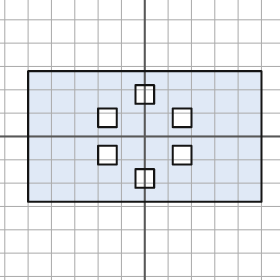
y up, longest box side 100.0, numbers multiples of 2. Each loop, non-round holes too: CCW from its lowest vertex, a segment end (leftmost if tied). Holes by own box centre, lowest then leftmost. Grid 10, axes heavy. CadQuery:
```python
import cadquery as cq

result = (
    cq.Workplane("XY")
    .moveTo(-50.0, -28.0)
    .lineTo(50.0, -28.0)
    .lineTo(50.0, 28.0)
    .lineTo(-50.0, 28.0)
    .close()
    .moveTo(-4.0, -22.0)
    .lineTo(4.0, -22.0)
    .lineTo(4.0, -14.0)
    .lineTo(-4.0, -14.0)
    .close()
    .moveTo(-20.0, -12.0)
    .lineTo(-12.0, -12.0)
    .lineTo(-12.0, -4.0)
    .lineTo(-20.0, -4.0)
    .close()
    .moveTo(12.0, -12.0)
    .lineTo(20.0, -12.0)
    .lineTo(20.0, -4.0)
    .lineTo(12.0, -4.0)
    .close()
    .moveTo(-20.0, 4.0)
    .lineTo(-12.0, 4.0)
    .lineTo(-12.0, 12.0)
    .lineTo(-20.0, 12.0)
    .close()
    .moveTo(12.0, 4.0)
    .lineTo(20.0, 4.0)
    .lineTo(20.0, 12.0)
    .lineTo(12.0, 12.0)
    .close()
    .moveTo(-4.0, 14.0)
    .lineTo(4.0, 14.0)
    .lineTo(4.0, 22.0)
    .lineTo(-4.0, 22.0)
    .close()
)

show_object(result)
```